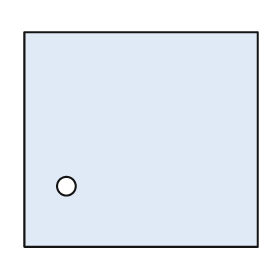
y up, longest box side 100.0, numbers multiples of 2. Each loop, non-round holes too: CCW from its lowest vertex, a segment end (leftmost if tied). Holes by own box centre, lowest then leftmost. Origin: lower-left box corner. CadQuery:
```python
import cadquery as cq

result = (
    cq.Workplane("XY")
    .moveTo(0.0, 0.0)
    .lineTo(100.0, 0.0)
    .lineTo(100.0, 92.0)
    .lineTo(0.0, 92.0)
    .close()
    .moveTo(18.0, 26.0)
    .circle(4.0)
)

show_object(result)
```